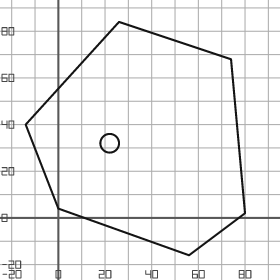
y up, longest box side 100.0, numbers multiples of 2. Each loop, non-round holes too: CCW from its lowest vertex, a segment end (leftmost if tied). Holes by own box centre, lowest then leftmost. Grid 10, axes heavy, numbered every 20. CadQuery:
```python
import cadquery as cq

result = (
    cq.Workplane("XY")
    .moveTo(56.0, -16.0)
    .lineTo(80.0, 2.0)
    .lineTo(74.0, 68.0)
    .lineTo(26.0, 84.0)
    .lineTo(-14.0, 40.0)
    .lineTo(0.0, 4.0)
    .close()
    .moveTo(22.0, 32.0)
    .circle(4.0)
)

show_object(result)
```